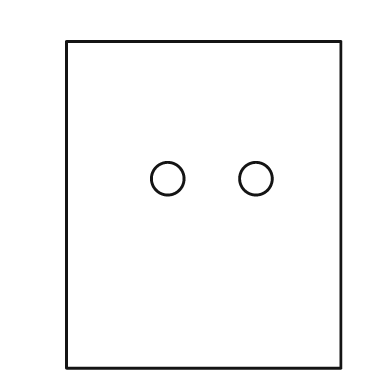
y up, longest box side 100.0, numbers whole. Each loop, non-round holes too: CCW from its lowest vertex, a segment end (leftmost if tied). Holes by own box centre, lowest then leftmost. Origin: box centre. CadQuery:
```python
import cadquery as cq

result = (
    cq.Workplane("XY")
    .moveTo(-42.0, -50.0)
    .lineTo(42.0, -50.0)
    .lineTo(42.0, 50.0)
    .lineTo(-42.0, 50.0)
    .close()
    .moveTo(-11.0, 8.0)
    .circle(5.0)
    .moveTo(16.0, 8.0)
    .circle(5.0)
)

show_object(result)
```